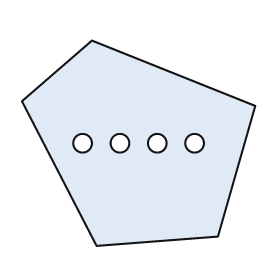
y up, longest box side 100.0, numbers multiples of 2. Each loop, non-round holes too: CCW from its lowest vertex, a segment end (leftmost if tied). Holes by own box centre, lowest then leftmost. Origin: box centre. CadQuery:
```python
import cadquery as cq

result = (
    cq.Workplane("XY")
    .moveTo(-18.0, -44.0)
    .lineTo(34.0, -40.0)
    .lineTo(50.0, 16.0)
    .lineTo(-20.0, 44.0)
    .lineTo(-50.0, 18.0)
    .close()
    .moveTo(-24.0, 0.0)
    .circle(4.0)
    .moveTo(-8.0, 0.0)
    .circle(4.0)
    .moveTo(8.0, 0.0)
    .circle(4.0)
    .moveTo(24.0, 0.0)
    .circle(4.0)
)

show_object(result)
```